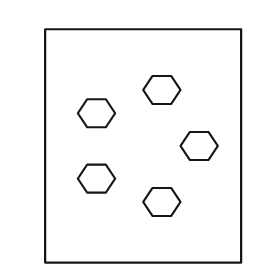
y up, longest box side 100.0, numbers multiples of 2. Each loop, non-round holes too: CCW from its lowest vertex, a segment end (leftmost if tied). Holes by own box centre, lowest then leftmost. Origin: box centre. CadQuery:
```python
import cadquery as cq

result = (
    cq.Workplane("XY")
    .moveTo(-42.0, -50.0)
    .lineTo(42.0, -50.0)
    .lineTo(42.0, 50.0)
    .lineTo(-42.0, 50.0)
    .close()
    .moveTo(4.0, -30.0)
    .lineTo(12.0, -30.0)
    .lineTo(16.0, -24.0)
    .lineTo(12.0, -18.0)
    .lineTo(4.0, -18.0)
    .lineTo(0.0, -24.0)
    .close()
    .moveTo(-24.0, -20.0)
    .lineTo(-16.0, -20.0)
    .lineTo(-12.0, -14.0)
    .lineTo(-16.0, -8.0)
    .lineTo(-24.0, -8.0)
    .lineTo(-28.0, -14.0)
    .close()
    .moveTo(20.0, -6.0)
    .lineTo(28.0, -6.0)
    .lineTo(32.0, 0.0)
    .lineTo(28.0, 6.0)
    .lineTo(20.0, 6.0)
    .lineTo(16.0, 0.0)
    .close()
    .moveTo(-24.0, 8.0)
    .lineTo(-16.0, 8.0)
    .lineTo(-12.0, 14.0)
    .lineTo(-16.0, 20.0)
    .lineTo(-24.0, 20.0)
    .lineTo(-28.0, 14.0)
    .close()
    .moveTo(4.0, 18.0)
    .lineTo(12.0, 18.0)
    .lineTo(16.0, 24.0)
    .lineTo(12.0, 30.0)
    .lineTo(4.0, 30.0)
    .lineTo(0.0, 24.0)
    .close()
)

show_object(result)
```